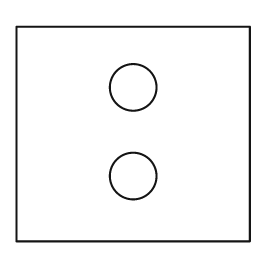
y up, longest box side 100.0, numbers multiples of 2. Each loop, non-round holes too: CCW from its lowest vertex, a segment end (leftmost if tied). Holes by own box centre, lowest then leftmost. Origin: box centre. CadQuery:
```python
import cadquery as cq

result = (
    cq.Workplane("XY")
    .moveTo(-50.0, -46.0)
    .lineTo(50.0, -46.0)
    .lineTo(50.0, 46.0)
    .lineTo(-50.0, 46.0)
    .close()
    .moveTo(0.0, -18.0)
    .circle(10.0)
    .moveTo(0.0, 20.0)
    .circle(10.0)
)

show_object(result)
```